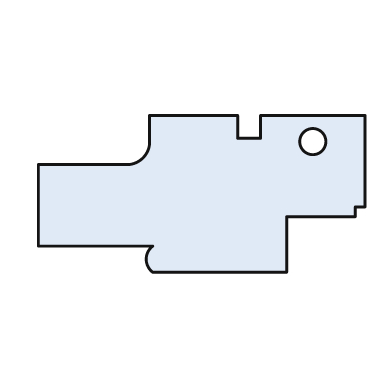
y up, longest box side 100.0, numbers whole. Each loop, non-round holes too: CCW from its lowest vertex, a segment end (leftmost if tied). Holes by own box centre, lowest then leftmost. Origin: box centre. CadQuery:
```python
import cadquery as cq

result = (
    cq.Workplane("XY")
    .moveTo(-15.0, -24.0)
    .lineTo(26.0, -24.0)
    .lineTo(26.0, -7.0)
    .lineTo(47.0, -7.0)
    .lineTo(47.0, -4.0)
    .lineTo(50.0, -4.0)
    .lineTo(50.0, 24.0)
    .lineTo(18.0, 24.0)
    .lineTo(18.0, 17.0)
    .lineTo(11.0, 17.0)
    .lineTo(11.0, 24.0)
    .lineTo(-16.0, 24.0)
    .lineTo(-16.0, 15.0)
    .threePointArc((-18.0, 11.0), (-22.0, 9.0))
    .lineTo(-50.0, 9.0)
    .lineTo(-50.0, -16.0)
    .lineTo(-15.0, -16.0)
    .threePointArc((-17.0, -20.0), (-15.0, -24.0))
    .close()
    .moveTo(34.0, 16.0)
    .circle(4.0)
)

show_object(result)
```